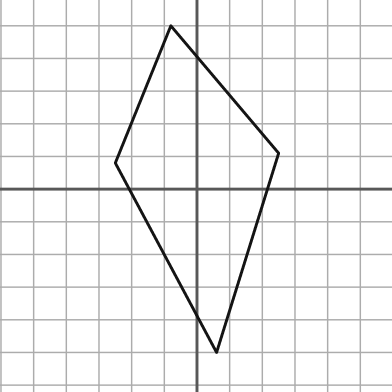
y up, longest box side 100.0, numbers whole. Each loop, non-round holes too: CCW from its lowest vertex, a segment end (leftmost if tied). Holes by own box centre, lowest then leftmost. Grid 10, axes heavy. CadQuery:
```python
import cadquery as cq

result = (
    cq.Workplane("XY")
    .moveTo(6.0, -50.0)
    .lineTo(25.0, 11.0)
    .lineTo(-8.0, 50.0)
    .lineTo(-25.0, 8.0)
    .close()
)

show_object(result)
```